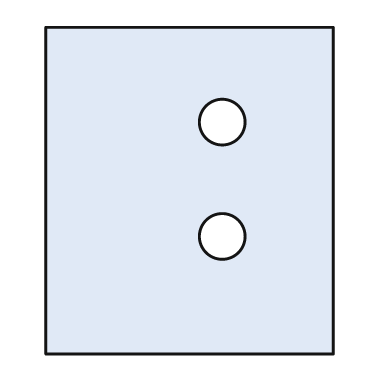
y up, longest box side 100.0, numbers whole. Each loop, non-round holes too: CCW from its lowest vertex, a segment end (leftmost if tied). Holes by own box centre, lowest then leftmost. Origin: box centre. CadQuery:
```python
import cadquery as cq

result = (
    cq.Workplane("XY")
    .moveTo(-44.0, -50.0)
    .lineTo(44.0, -50.0)
    .lineTo(44.0, 50.0)
    .lineTo(-44.0, 50.0)
    .close()
    .moveTo(10.0, -14.0)
    .circle(7.0)
    .moveTo(10.0, 21.0)
    .circle(7.0)
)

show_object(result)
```